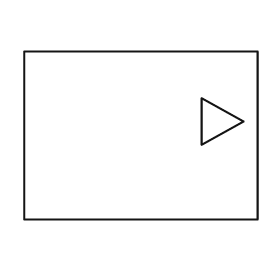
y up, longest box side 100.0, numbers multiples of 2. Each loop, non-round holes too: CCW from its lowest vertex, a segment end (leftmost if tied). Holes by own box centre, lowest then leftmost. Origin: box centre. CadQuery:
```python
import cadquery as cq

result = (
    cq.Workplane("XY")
    .moveTo(-50.0, -36.0)
    .lineTo(50.0, -36.0)
    .lineTo(50.0, 36.0)
    .lineTo(-50.0, 36.0)
    .close()
    .moveTo(26.0, -4.0)
    .lineTo(44.0, 6.0)
    .lineTo(26.0, 16.0)
    .close()
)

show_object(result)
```